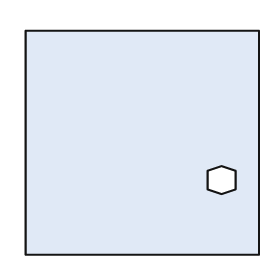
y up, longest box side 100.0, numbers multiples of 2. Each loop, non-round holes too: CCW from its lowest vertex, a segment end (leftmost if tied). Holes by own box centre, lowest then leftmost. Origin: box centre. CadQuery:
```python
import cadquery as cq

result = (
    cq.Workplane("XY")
    .moveTo(-50.0, -48.0)
    .lineTo(50.0, -48.0)
    .lineTo(50.0, 48.0)
    .lineTo(-50.0, 48.0)
    .close()
    .moveTo(34.0, -22.0)
    .lineTo(40.0, -20.0)
    .lineTo(40.0, -12.0)
    .lineTo(34.0, -10.0)
    .lineTo(28.0, -12.0)
    .lineTo(28.0, -20.0)
    .close()
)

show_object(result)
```